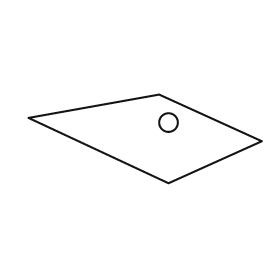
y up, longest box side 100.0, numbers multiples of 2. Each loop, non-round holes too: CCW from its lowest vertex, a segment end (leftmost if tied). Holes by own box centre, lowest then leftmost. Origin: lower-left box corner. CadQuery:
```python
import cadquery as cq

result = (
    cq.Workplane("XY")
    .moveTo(60.0, 0.0)
    .lineTo(100.0, 18.0)
    .lineTo(56.0, 38.0)
    .lineTo(0.0, 28.0)
    .close()
    .moveTo(60.0, 26.0)
    .circle(4.0)
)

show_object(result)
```